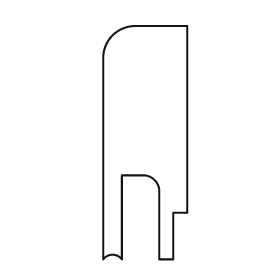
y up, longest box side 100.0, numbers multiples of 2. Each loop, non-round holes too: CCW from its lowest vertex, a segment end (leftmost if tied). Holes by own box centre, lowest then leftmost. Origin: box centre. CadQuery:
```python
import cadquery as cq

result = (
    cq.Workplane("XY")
    .moveTo(-18.0, -50.0)
    .threePointArc((-14.0, -48.0), (-10.0, -50.0))
    .lineTo(-10.0, -14.0)
    .lineTo(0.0, -14.0)
    .threePointArc((4.0, -16.0), (6.0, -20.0))
    .lineTo(6.0, -50.0)
    .lineTo(12.0, -50.0)
    .lineTo(12.0, -30.0)
    .lineTo(18.0, -30.0)
    .lineTo(18.0, 50.0)
    .lineTo(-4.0, 50.0)
    .threePointArc((-14.0, 46.0), (-18.0, 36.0))
    .close()
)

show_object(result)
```